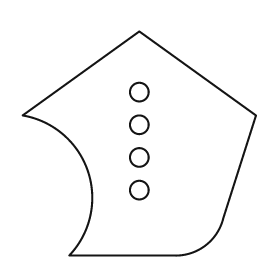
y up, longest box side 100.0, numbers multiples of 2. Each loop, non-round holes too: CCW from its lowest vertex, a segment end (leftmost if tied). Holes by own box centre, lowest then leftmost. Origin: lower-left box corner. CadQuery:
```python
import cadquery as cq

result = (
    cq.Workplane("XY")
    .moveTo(20.0, 0.0)
    .lineTo(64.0, 0.0)
    .threePointArc((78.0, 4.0), (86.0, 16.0))
    .lineTo(100.0, 60.0)
    .lineTo(50.0, 96.0)
    .lineTo(0.0, 60.0)
    .threePointArc((28.0, 36.0), (20.0, 0.0))
    .close()
    .moveTo(50.0, 28.0)
    .circle(4.0)
    .moveTo(50.0, 42.0)
    .circle(4.0)
    .moveTo(50.0, 56.0)
    .circle(4.0)
    .moveTo(50.0, 70.0)
    .circle(4.0)
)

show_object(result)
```